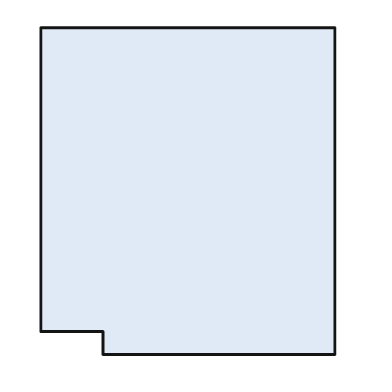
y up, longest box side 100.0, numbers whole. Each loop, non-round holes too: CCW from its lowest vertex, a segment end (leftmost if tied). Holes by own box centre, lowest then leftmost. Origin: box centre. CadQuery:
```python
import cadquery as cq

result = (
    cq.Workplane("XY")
    .moveTo(-26.0, -50.0)
    .lineTo(45.0, -50.0)
    .lineTo(45.0, 50.0)
    .lineTo(-45.0, 50.0)
    .lineTo(-45.0, -43.0)
    .lineTo(-26.0, -43.0)
    .close()
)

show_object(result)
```